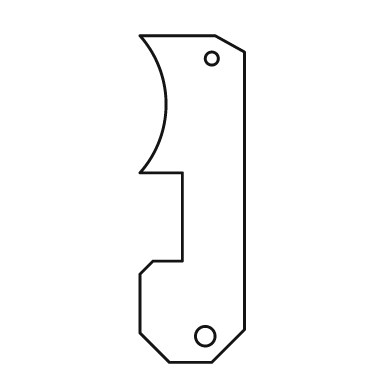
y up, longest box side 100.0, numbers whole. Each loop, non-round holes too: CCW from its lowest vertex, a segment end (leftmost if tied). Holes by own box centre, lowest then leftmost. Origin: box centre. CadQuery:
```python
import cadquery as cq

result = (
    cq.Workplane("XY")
    .moveTo(-7.0, -50.0)
    .lineTo(6.0, -50.0)
    .lineTo(16.0, -40.0)
    .lineTo(16.0, 45.0)
    .lineTo(7.0, 50.0)
    .lineTo(-16.0, 50.0)
    .threePointArc((-8.0, 29.0), (-16.0, 8.0))
    .lineTo(-3.0, 8.0)
    .lineTo(-3.0, -19.0)
    .lineTo(-12.0, -19.0)
    .lineTo(-16.0, -23.0)
    .lineTo(-16.0, -41.0)
    .close()
    .moveTo(4.0, -42.0)
    .circle(3.0)
    .moveTo(6.0, 43.0)
    .circle(2.0)
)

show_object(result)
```